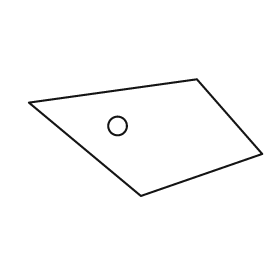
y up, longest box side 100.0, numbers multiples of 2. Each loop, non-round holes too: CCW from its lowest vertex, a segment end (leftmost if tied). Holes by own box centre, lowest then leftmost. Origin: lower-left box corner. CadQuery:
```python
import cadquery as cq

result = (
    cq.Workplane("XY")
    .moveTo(48.0, 0.0)
    .lineTo(100.0, 18.0)
    .lineTo(72.0, 50.0)
    .lineTo(0.0, 40.0)
    .close()
    .moveTo(38.0, 30.0)
    .circle(4.0)
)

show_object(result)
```